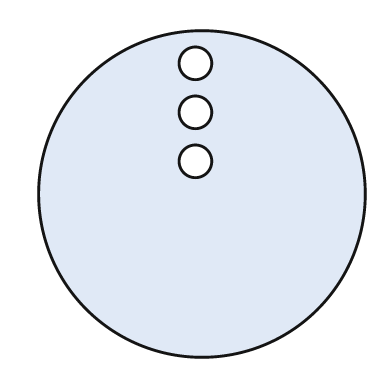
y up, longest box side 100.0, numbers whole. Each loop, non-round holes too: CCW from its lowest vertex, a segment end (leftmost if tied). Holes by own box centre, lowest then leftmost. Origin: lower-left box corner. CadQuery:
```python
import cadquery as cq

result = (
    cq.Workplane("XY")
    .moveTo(50.0, 50.0)
    .circle(50.0)
    .moveTo(48.0, 60.0)
    .circle(5.0)
    .moveTo(48.0, 75.0)
    .circle(5.0)
    .moveTo(48.0, 90.0)
    .circle(5.0)
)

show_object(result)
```